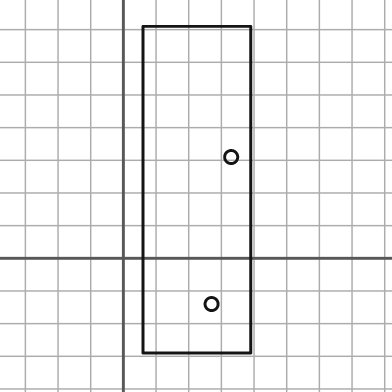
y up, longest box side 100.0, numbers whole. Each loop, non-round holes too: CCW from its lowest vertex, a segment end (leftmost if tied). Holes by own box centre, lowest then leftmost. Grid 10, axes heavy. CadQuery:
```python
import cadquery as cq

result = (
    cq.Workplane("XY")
    .moveTo(6.0, -29.0)
    .lineTo(39.0, -29.0)
    .lineTo(39.0, 71.0)
    .lineTo(6.0, 71.0)
    .close()
    .moveTo(27.0, -14.0)
    .circle(2.0)
    .moveTo(33.0, 31.0)
    .circle(2.0)
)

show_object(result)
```